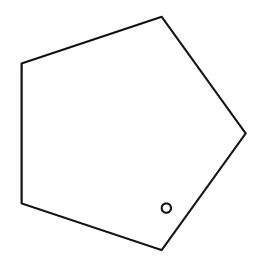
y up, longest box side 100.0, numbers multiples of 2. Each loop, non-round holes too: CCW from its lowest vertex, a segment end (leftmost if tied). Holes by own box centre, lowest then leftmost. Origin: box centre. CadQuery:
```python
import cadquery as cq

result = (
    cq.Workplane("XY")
    .moveTo(12.0, -50.0)
    .lineTo(48.0, 0.0)
    .lineTo(12.0, 50.0)
    .lineTo(-48.0, 30.0)
    .lineTo(-48.0, -30.0)
    .close()
    .moveTo(14.0, -32.0)
    .circle(2.0)
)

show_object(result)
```